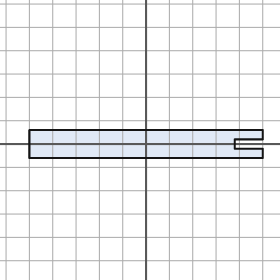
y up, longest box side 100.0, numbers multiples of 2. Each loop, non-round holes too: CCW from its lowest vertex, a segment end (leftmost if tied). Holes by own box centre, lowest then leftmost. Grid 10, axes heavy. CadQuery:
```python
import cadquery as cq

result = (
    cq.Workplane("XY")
    .moveTo(-50.0, -6.0)
    .lineTo(50.0, -6.0)
    .lineTo(50.0, -2.0)
    .lineTo(38.0, -2.0)
    .lineTo(38.0, 2.0)
    .lineTo(50.0, 2.0)
    .lineTo(50.0, 6.0)
    .lineTo(-50.0, 6.0)
    .close()
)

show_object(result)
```